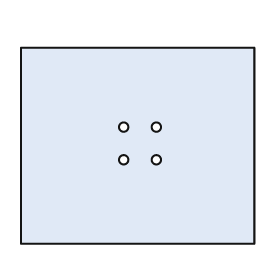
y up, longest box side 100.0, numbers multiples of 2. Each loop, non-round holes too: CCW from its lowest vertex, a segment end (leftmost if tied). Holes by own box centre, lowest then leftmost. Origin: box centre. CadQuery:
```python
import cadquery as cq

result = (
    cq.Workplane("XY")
    .moveTo(-50.0, -42.0)
    .lineTo(50.0, -42.0)
    .lineTo(50.0, 42.0)
    .lineTo(-50.0, 42.0)
    .close()
    .moveTo(-6.0, -6.0)
    .circle(2.0)
    .moveTo(8.0, -6.0)
    .circle(2.0)
    .moveTo(-6.0, 8.0)
    .circle(2.0)
    .moveTo(8.0, 8.0)
    .circle(2.0)
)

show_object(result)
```